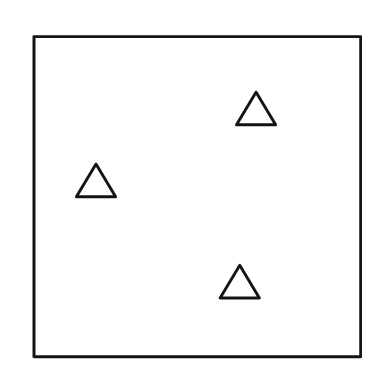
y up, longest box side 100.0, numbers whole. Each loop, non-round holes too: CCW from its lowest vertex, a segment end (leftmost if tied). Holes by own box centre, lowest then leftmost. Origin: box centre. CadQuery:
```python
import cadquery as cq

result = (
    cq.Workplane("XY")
    .moveTo(-50.0, -49.0)
    .lineTo(50.0, -49.0)
    .lineTo(50.0, 49.0)
    .lineTo(-50.0, 49.0)
    .close()
    .moveTo(7.0, -31.0)
    .lineTo(19.0, -31.0)
    .lineTo(13.0, -21.0)
    .close()
    .moveTo(-37.0, 0.0)
    .lineTo(-25.0, 0.0)
    .lineTo(-31.0, 10.0)
    .close()
    .moveTo(12.0, 22.0)
    .lineTo(24.0, 22.0)
    .lineTo(18.0, 32.0)
    .close()
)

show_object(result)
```